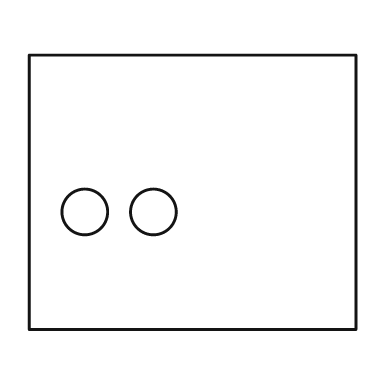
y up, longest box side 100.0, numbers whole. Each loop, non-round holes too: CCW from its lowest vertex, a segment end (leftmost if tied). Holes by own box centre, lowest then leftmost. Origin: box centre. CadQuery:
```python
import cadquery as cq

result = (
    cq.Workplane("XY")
    .moveTo(-50.0, -42.0)
    .lineTo(50.0, -42.0)
    .lineTo(50.0, 42.0)
    .lineTo(-50.0, 42.0)
    .close()
    .moveTo(-33.0, -6.0)
    .circle(7.0)
    .moveTo(-12.0, -6.0)
    .circle(7.0)
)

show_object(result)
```